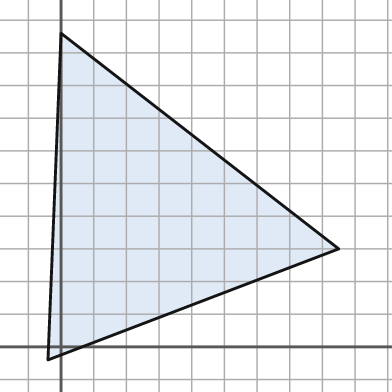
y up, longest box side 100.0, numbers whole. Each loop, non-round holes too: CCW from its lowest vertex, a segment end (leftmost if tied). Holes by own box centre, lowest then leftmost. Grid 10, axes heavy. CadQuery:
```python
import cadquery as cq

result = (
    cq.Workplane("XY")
    .moveTo(-4.0, -4.0)
    .lineTo(85.0, 30.0)
    .lineTo(0.0, 96.0)
    .close()
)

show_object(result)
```